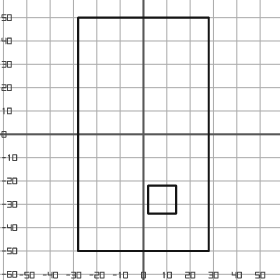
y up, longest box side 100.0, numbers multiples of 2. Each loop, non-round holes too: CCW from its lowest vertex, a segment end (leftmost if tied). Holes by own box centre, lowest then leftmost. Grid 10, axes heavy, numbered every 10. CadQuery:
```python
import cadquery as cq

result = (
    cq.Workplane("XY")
    .moveTo(-28.0, -50.0)
    .lineTo(28.0, -50.0)
    .lineTo(28.0, 50.0)
    .lineTo(-28.0, 50.0)
    .close()
    .moveTo(2.0, -34.0)
    .lineTo(14.0, -34.0)
    .lineTo(14.0, -22.0)
    .lineTo(2.0, -22.0)
    .close()
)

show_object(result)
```